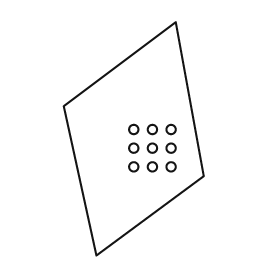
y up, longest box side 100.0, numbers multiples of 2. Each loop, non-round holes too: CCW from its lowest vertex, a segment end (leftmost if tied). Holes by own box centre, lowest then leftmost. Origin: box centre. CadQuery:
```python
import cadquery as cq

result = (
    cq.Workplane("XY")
    .moveTo(-16.0, -50.0)
    .lineTo(30.0, -16.0)
    .lineTo(18.0, 50.0)
    .lineTo(-30.0, 14.0)
    .close()
    .moveTo(0.0, -12.0)
    .circle(2.0)
    .moveTo(8.0, -12.0)
    .circle(2.0)
    .moveTo(16.0, -12.0)
    .circle(2.0)
    .moveTo(0.0, -4.0)
    .circle(2.0)
    .moveTo(8.0, -4.0)
    .circle(2.0)
    .moveTo(16.0, -4.0)
    .circle(2.0)
    .moveTo(0.0, 4.0)
    .circle(2.0)
    .moveTo(8.0, 4.0)
    .circle(2.0)
    .moveTo(16.0, 4.0)
    .circle(2.0)
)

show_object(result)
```